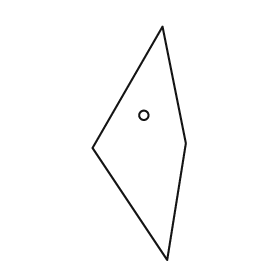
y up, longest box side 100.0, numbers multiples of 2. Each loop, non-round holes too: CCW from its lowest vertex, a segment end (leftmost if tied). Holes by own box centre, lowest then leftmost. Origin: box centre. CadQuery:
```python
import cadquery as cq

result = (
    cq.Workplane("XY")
    .moveTo(12.0, -50.0)
    .lineTo(20.0, 0.0)
    .lineTo(10.0, 50.0)
    .lineTo(-20.0, -2.0)
    .close()
    .moveTo(2.0, 12.0)
    .circle(2.0)
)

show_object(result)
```